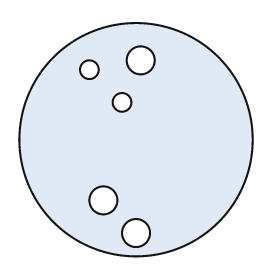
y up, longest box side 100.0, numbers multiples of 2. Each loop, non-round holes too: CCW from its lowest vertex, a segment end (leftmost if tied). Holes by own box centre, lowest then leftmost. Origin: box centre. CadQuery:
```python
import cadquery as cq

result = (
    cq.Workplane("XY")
    .moveTo(0.0, 0.0)
    .circle(50.0)
    .moveTo(0.0, -40.0)
    .circle(6.0)
    .moveTo(-14.0, -26.0)
    .circle(6.0)
    .moveTo(-6.0, 16.0)
    .circle(4.0)
    .moveTo(-20.0, 30.0)
    .circle(4.0)
    .moveTo(2.0, 34.0)
    .circle(6.0)
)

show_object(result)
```